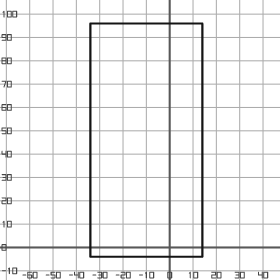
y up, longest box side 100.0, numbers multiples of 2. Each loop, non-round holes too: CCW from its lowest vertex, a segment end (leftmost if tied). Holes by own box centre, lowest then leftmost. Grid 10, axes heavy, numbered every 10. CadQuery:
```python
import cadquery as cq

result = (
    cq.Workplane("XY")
    .moveTo(-34.0, -4.0)
    .lineTo(14.0, -4.0)
    .lineTo(14.0, 96.0)
    .lineTo(-34.0, 96.0)
    .close()
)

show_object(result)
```